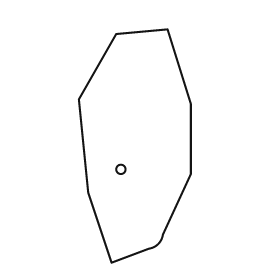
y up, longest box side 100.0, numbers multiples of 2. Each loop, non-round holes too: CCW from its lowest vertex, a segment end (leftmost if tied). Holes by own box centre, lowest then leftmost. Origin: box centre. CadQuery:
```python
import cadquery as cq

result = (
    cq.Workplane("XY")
    .moveTo(-10.0, -50.0)
    .lineTo(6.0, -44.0)
    .threePointArc((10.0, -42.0), (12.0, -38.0))
    .lineTo(24.0, -12.0)
    .lineTo(24.0, 18.0)
    .lineTo(14.0, 50.0)
    .lineTo(-8.0, 48.0)
    .lineTo(-24.0, 20.0)
    .lineTo(-20.0, -20.0)
    .close()
    .moveTo(-6.0, -10.0)
    .circle(2.0)
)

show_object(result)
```